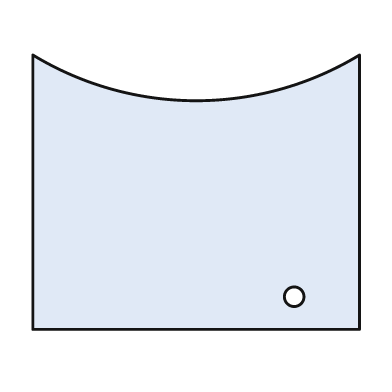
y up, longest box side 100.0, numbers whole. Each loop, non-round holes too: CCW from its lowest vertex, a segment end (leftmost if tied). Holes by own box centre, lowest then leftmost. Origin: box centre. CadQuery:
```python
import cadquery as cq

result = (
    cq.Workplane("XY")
    .moveTo(-50.0, -42.0)
    .lineTo(50.0, -42.0)
    .lineTo(50.0, 42.0)
    .threePointArc((0.0, 28.0), (-50.0, 42.0))
    .close()
    .moveTo(30.0, -32.0)
    .circle(3.0)
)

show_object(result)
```